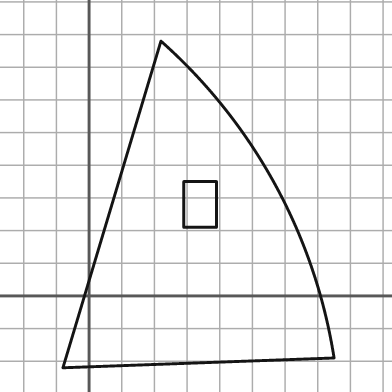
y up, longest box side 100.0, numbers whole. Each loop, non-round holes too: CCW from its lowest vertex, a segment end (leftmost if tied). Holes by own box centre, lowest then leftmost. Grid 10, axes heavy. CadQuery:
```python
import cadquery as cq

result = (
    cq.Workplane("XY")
    .moveTo(-8.0, -22.0)
    .lineTo(75.0, -19.0)
    .threePointArc((57.0, 34.0), (22.0, 78.0))
    .close()
    .moveTo(29.0, 21.0)
    .lineTo(39.0, 21.0)
    .lineTo(39.0, 35.0)
    .lineTo(29.0, 35.0)
    .close()
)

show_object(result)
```